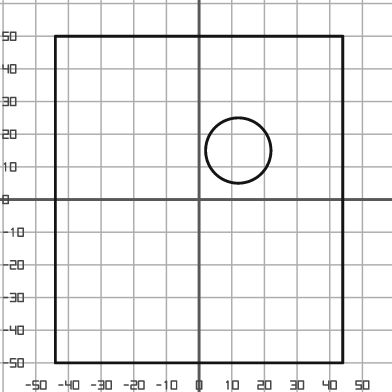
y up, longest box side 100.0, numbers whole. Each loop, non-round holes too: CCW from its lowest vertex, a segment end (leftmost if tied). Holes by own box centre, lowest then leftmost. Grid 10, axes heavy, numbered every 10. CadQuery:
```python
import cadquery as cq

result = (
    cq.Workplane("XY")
    .moveTo(-44.0, -50.0)
    .lineTo(44.0, -50.0)
    .lineTo(44.0, 50.0)
    .lineTo(-44.0, 50.0)
    .close()
    .moveTo(12.0, 15.0)
    .circle(10.0)
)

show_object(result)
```